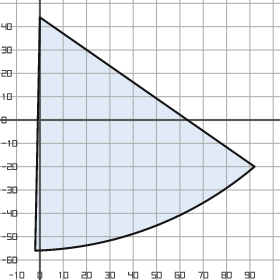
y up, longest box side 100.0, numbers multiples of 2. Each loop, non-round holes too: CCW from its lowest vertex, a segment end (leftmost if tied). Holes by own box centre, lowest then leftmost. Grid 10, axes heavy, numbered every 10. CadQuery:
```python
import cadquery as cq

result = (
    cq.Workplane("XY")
    .moveTo(-2.0, -56.0)
    .threePointArc((48.0, -46.0), (92.0, -20.0))
    .lineTo(0.0, 44.0)
    .close()
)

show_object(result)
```